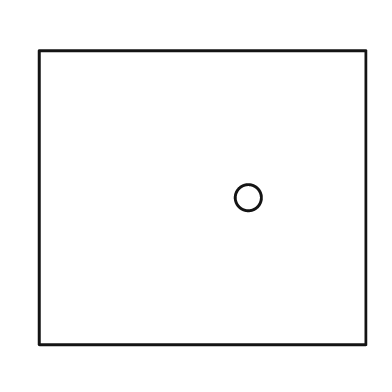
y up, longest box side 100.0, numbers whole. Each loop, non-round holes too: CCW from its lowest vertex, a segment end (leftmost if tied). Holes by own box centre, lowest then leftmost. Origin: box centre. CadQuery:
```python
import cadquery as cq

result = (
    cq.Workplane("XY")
    .moveTo(-50.0, -45.0)
    .lineTo(50.0, -45.0)
    .lineTo(50.0, 45.0)
    .lineTo(-50.0, 45.0)
    .close()
    .moveTo(14.0, 0.0)
    .circle(4.0)
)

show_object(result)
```